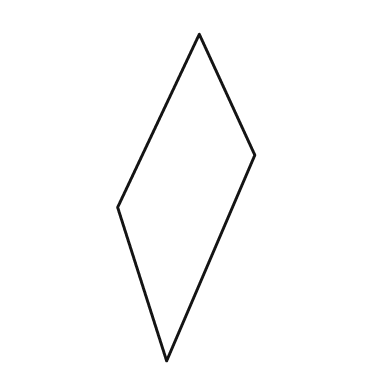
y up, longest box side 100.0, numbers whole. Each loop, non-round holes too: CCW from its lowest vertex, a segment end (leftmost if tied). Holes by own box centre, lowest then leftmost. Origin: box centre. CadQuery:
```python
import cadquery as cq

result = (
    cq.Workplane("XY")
    .moveTo(-6.0, -50.0)
    .lineTo(21.0, 13.0)
    .lineTo(4.0, 50.0)
    .lineTo(-21.0, -3.0)
    .close()
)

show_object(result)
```